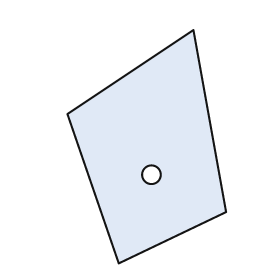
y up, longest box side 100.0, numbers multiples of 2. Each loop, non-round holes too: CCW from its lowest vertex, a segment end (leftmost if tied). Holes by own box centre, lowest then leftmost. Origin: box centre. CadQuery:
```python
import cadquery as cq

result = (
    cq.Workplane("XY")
    .moveTo(-12.0, -50.0)
    .lineTo(34.0, -28.0)
    .lineTo(20.0, 50.0)
    .lineTo(-34.0, 14.0)
    .close()
    .moveTo(2.0, -12.0)
    .circle(4.0)
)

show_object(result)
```